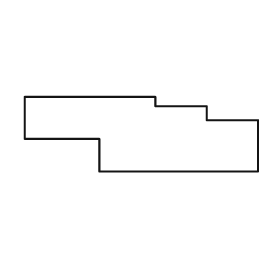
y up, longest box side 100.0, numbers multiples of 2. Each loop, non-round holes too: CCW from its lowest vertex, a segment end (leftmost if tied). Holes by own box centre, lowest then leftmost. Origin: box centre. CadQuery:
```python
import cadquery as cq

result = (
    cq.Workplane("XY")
    .moveTo(-18.0, -16.0)
    .lineTo(50.0, -16.0)
    .lineTo(50.0, 6.0)
    .lineTo(28.0, 6.0)
    .lineTo(28.0, 12.0)
    .lineTo(6.0, 12.0)
    .lineTo(6.0, 16.0)
    .lineTo(-50.0, 16.0)
    .lineTo(-50.0, -2.0)
    .lineTo(-18.0, -2.0)
    .close()
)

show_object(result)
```